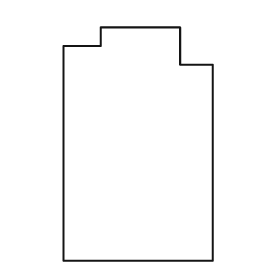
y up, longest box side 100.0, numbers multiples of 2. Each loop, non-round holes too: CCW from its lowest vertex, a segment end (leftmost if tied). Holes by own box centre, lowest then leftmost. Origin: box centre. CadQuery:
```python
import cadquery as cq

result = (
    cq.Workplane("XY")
    .moveTo(-32.0, -50.0)
    .lineTo(32.0, -50.0)
    .lineTo(32.0, 34.0)
    .lineTo(18.0, 34.0)
    .lineTo(18.0, 50.0)
    .lineTo(-16.0, 50.0)
    .lineTo(-16.0, 42.0)
    .lineTo(-32.0, 42.0)
    .close()
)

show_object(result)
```